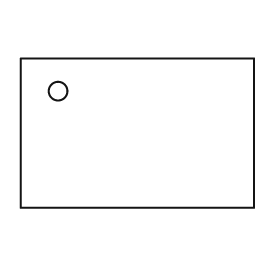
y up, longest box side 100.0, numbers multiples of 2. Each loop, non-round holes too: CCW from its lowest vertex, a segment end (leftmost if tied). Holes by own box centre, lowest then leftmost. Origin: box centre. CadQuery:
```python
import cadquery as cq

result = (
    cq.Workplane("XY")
    .moveTo(-50.0, -32.0)
    .lineTo(50.0, -32.0)
    .lineTo(50.0, 32.0)
    .lineTo(-50.0, 32.0)
    .close()
    .moveTo(-34.0, 18.0)
    .circle(4.0)
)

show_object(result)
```